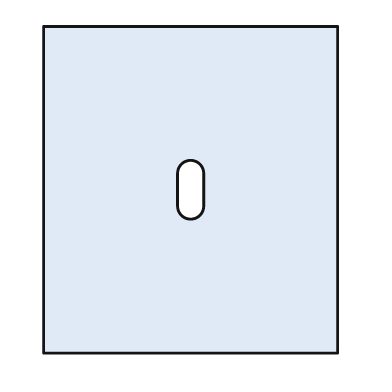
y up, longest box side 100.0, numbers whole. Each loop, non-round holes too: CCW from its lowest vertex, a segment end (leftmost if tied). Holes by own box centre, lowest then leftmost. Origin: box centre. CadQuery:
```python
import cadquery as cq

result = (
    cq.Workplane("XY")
    .moveTo(-45.0, -50.0)
    .lineTo(45.0, -50.0)
    .lineTo(45.0, 50.0)
    .lineTo(-45.0, 50.0)
    .close()
    .moveTo(-4.0, -5.0)
    .threePointArc((0.0, -9.0), (4.0, -5.0))
    .lineTo(4.0, 5.0)
    .threePointArc((0.0, 9.0), (-4.0, 5.0))
    .close()
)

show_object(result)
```